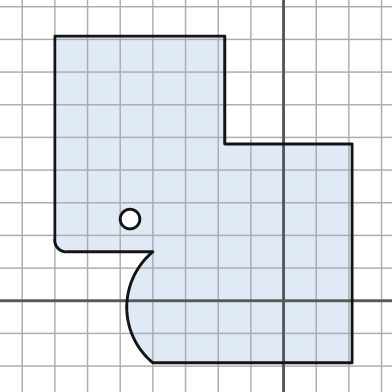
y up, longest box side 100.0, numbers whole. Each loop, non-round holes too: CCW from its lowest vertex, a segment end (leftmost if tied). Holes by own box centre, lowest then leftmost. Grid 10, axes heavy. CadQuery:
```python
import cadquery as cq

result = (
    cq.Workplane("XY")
    .moveTo(-40.0, -19.0)
    .lineTo(21.0, -19.0)
    .lineTo(21.0, 48.0)
    .lineTo(-18.0, 48.0)
    .lineTo(-18.0, 81.0)
    .lineTo(-70.0, 81.0)
    .lineTo(-70.0, 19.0)
    .threePointArc((-69.0, 16.0), (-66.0, 15.0))
    .lineTo(-40.0, 15.0)
    .threePointArc((-48.0, -2.0), (-40.0, -19.0))
    .close()
    .moveTo(-47.0, 25.0)
    .circle(3.0)
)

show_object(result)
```